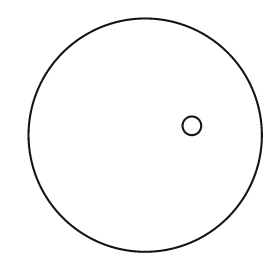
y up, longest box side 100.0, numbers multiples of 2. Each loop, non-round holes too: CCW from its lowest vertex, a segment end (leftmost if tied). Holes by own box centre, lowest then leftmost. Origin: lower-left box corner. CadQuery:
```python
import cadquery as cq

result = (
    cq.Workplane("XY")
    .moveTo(50.0, 50.0)
    .circle(50.0)
    .moveTo(70.0, 54.0)
    .circle(4.0)
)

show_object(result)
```